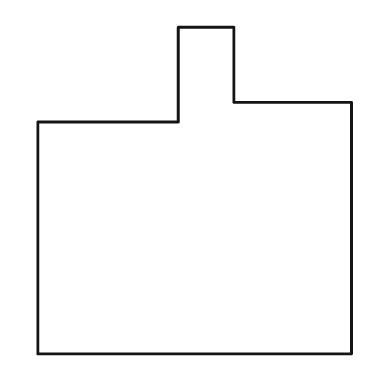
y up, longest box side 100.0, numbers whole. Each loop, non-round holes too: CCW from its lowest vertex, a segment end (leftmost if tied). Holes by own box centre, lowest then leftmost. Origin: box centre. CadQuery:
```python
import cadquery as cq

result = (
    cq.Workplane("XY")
    .moveTo(-48.0, -50.0)
    .lineTo(48.0, -50.0)
    .lineTo(48.0, 27.0)
    .lineTo(12.0, 27.0)
    .lineTo(12.0, 50.0)
    .lineTo(-5.0, 50.0)
    .lineTo(-5.0, 21.0)
    .lineTo(-48.0, 21.0)
    .close()
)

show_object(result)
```